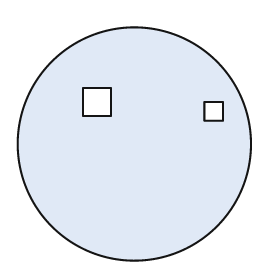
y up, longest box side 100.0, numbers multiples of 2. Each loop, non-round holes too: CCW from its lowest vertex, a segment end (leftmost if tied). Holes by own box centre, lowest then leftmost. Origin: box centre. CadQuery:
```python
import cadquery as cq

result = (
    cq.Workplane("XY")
    .moveTo(0.0, 0.0)
    .circle(50.0)
    .moveTo(30.0, 10.0)
    .lineTo(38.0, 10.0)
    .lineTo(38.0, 18.0)
    .lineTo(30.0, 18.0)
    .close()
    .moveTo(-22.0, 12.0)
    .lineTo(-10.0, 12.0)
    .lineTo(-10.0, 24.0)
    .lineTo(-22.0, 24.0)
    .close()
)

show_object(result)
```